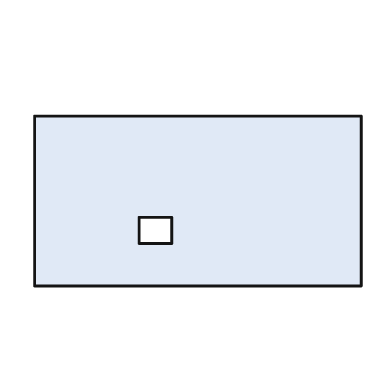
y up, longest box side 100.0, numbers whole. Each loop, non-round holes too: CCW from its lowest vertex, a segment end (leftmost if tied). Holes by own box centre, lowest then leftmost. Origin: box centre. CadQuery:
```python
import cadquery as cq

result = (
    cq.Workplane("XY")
    .moveTo(-50.0, -26.0)
    .lineTo(50.0, -26.0)
    .lineTo(50.0, 26.0)
    .lineTo(-50.0, 26.0)
    .close()
    .moveTo(-18.0, -13.0)
    .lineTo(-8.0, -13.0)
    .lineTo(-8.0, -5.0)
    .lineTo(-18.0, -5.0)
    .close()
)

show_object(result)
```